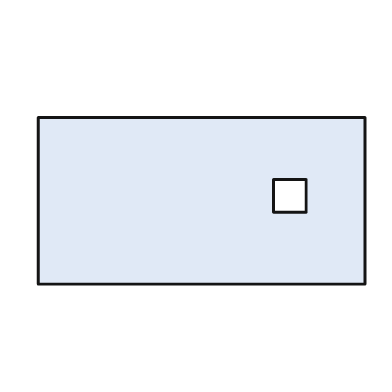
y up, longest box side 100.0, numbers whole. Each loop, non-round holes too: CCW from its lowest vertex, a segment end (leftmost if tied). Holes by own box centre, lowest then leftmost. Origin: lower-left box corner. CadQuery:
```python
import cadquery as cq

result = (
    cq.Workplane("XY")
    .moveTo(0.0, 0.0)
    .lineTo(100.0, 0.0)
    .lineTo(100.0, 51.0)
    .lineTo(0.0, 51.0)
    .close()
    .moveTo(72.0, 22.0)
    .lineTo(82.0, 22.0)
    .lineTo(82.0, 32.0)
    .lineTo(72.0, 32.0)
    .close()
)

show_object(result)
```